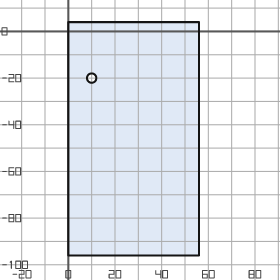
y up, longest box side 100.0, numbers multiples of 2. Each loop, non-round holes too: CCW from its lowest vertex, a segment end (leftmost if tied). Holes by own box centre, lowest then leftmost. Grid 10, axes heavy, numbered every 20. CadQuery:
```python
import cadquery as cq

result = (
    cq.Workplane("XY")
    .moveTo(0.0, -96.0)
    .lineTo(56.0, -96.0)
    .lineTo(56.0, 4.0)
    .lineTo(0.0, 4.0)
    .close()
    .moveTo(10.0, -20.0)
    .circle(2.0)
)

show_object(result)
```